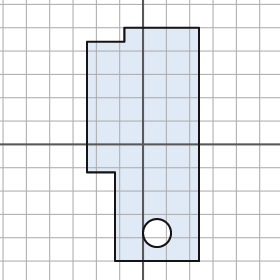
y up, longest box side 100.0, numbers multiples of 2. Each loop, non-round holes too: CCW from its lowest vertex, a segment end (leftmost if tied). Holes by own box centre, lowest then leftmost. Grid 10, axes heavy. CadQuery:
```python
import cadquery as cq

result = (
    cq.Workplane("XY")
    .moveTo(-12.0, -50.0)
    .lineTo(24.0, -50.0)
    .lineTo(24.0, 50.0)
    .lineTo(-8.0, 50.0)
    .lineTo(-8.0, 44.0)
    .lineTo(-24.0, 44.0)
    .lineTo(-24.0, -12.0)
    .lineTo(-12.0, -12.0)
    .close()
    .moveTo(6.0, -38.0)
    .circle(6.0)
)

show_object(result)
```